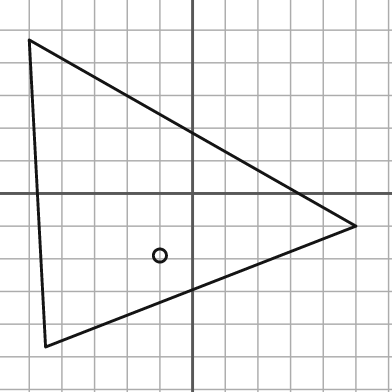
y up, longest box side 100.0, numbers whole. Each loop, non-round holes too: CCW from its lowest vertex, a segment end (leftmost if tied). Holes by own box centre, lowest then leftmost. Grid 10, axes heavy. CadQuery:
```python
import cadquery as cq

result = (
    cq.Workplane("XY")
    .moveTo(-45.0, -47.0)
    .lineTo(50.0, -10.0)
    .lineTo(-50.0, 47.0)
    .close()
    .moveTo(-10.0, -19.0)
    .circle(2.0)
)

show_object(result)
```